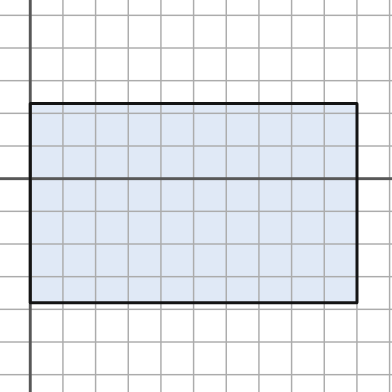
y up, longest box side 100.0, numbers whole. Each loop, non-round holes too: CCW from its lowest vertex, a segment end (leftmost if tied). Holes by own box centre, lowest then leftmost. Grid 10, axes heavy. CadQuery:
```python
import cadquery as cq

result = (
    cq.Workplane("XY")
    .moveTo(0.0, -38.0)
    .lineTo(100.0, -38.0)
    .lineTo(100.0, 23.0)
    .lineTo(0.0, 23.0)
    .close()
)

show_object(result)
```